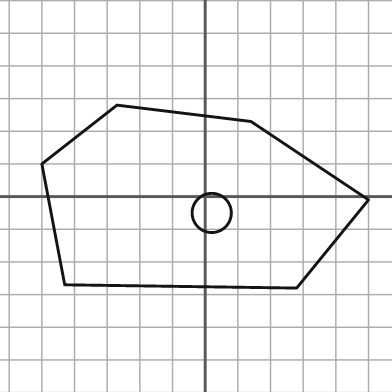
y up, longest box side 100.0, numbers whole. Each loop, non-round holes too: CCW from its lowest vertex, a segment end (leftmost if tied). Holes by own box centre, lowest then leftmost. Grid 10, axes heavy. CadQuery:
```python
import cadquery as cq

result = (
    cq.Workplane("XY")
    .moveTo(28.0, -28.0)
    .lineTo(50.0, -1.0)
    .lineTo(14.0, 23.0)
    .lineTo(-27.0, 28.0)
    .lineTo(-50.0, 10.0)
    .lineTo(-43.0, -27.0)
    .close()
    .moveTo(2.0, -5.0)
    .circle(6.0)
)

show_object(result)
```